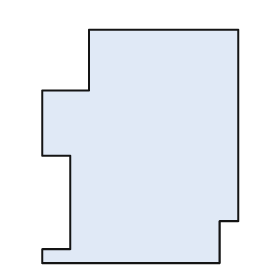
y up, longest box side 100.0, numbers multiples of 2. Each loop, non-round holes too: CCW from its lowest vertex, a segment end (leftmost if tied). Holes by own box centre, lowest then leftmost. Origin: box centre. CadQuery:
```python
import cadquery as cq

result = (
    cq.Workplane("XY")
    .moveTo(-42.0, -50.0)
    .lineTo(34.0, -50.0)
    .lineTo(34.0, -32.0)
    .lineTo(42.0, -32.0)
    .lineTo(42.0, 50.0)
    .lineTo(-22.0, 50.0)
    .lineTo(-22.0, 24.0)
    .lineTo(-42.0, 24.0)
    .lineTo(-42.0, -4.0)
    .lineTo(-30.0, -4.0)
    .lineTo(-30.0, -44.0)
    .lineTo(-42.0, -44.0)
    .close()
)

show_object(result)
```